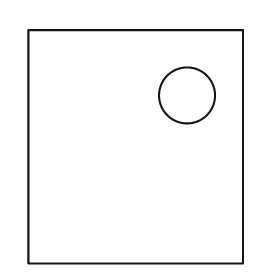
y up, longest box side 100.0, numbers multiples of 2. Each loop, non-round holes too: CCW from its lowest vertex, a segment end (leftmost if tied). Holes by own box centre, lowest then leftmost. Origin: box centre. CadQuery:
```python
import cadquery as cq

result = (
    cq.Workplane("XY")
    .moveTo(-46.0, -50.0)
    .lineTo(46.0, -50.0)
    .lineTo(46.0, 50.0)
    .lineTo(-46.0, 50.0)
    .close()
    .moveTo(22.0, 22.0)
    .circle(12.0)
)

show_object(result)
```